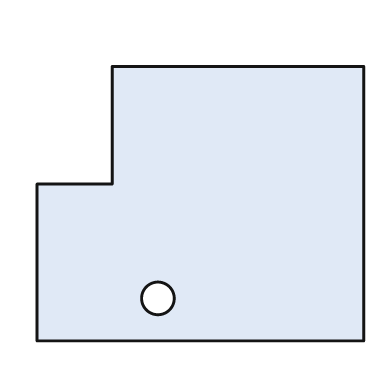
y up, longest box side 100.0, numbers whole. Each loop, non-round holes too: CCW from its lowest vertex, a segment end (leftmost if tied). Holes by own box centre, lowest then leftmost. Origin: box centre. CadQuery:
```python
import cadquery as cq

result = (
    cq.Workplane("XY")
    .moveTo(-50.0, -42.0)
    .lineTo(50.0, -42.0)
    .lineTo(50.0, 42.0)
    .lineTo(-27.0, 42.0)
    .lineTo(-27.0, 6.0)
    .lineTo(-50.0, 6.0)
    .close()
    .moveTo(-13.0, -29.0)
    .circle(5.0)
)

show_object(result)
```